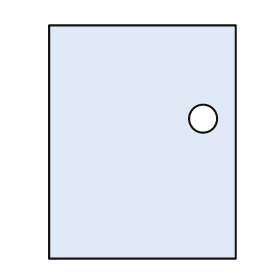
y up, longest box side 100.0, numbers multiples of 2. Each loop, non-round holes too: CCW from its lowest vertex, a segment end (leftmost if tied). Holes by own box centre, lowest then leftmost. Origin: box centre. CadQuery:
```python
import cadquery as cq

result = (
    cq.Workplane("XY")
    .moveTo(-40.0, -50.0)
    .lineTo(40.0, -50.0)
    .lineTo(40.0, 50.0)
    .lineTo(-40.0, 50.0)
    .close()
    .moveTo(26.0, 10.0)
    .circle(6.0)
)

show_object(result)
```